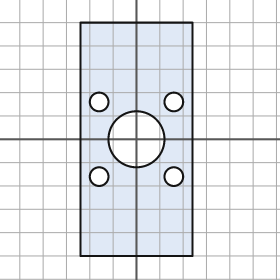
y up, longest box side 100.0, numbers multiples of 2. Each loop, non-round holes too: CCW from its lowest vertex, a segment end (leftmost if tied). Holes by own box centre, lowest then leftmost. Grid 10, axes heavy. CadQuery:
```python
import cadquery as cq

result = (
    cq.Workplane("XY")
    .moveTo(-24.0, -50.0)
    .lineTo(24.0, -50.0)
    .lineTo(24.0, 50.0)
    .lineTo(-24.0, 50.0)
    .close()
    .moveTo(-16.0, -16.0)
    .circle(4.0)
    .moveTo(16.0, -16.0)
    .circle(4.0)
    .moveTo(0.0, 0.0)
    .circle(12.0)
    .moveTo(-16.0, 16.0)
    .circle(4.0)
    .moveTo(16.0, 16.0)
    .circle(4.0)
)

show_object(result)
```